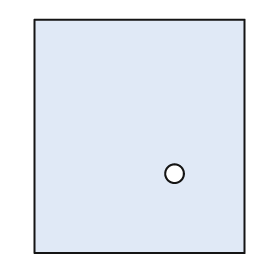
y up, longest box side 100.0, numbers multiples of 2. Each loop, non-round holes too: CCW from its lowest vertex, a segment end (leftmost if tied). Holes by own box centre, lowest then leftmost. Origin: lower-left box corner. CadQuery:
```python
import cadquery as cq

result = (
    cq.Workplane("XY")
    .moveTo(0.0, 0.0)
    .lineTo(90.0, 0.0)
    .lineTo(90.0, 100.0)
    .lineTo(0.0, 100.0)
    .close()
    .moveTo(60.0, 34.0)
    .circle(4.0)
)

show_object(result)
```